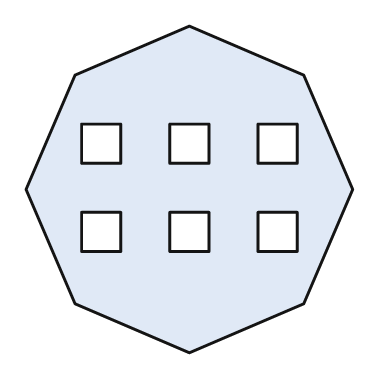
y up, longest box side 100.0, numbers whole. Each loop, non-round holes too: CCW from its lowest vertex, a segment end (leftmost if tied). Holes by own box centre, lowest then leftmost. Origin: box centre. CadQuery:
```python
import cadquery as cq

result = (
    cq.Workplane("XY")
    .moveTo(0.0, -50.0)
    .lineTo(35.0, -35.0)
    .lineTo(50.0, 0.0)
    .lineTo(35.0, 35.0)
    .lineTo(0.0, 50.0)
    .lineTo(-35.0, 35.0)
    .lineTo(-50.0, 0.0)
    .lineTo(-35.0, -35.0)
    .close()
    .moveTo(-33.0, -19.0)
    .lineTo(-21.0, -19.0)
    .lineTo(-21.0, -7.0)
    .lineTo(-33.0, -7.0)
    .close()
    .moveTo(-6.0, -19.0)
    .lineTo(6.0, -19.0)
    .lineTo(6.0, -7.0)
    .lineTo(-6.0, -7.0)
    .close()
    .moveTo(21.0, -19.0)
    .lineTo(33.0, -19.0)
    .lineTo(33.0, -7.0)
    .lineTo(21.0, -7.0)
    .close()
    .moveTo(-33.0, 8.0)
    .lineTo(-21.0, 8.0)
    .lineTo(-21.0, 20.0)
    .lineTo(-33.0, 20.0)
    .close()
    .moveTo(-6.0, 8.0)
    .lineTo(6.0, 8.0)
    .lineTo(6.0, 20.0)
    .lineTo(-6.0, 20.0)
    .close()
    .moveTo(21.0, 8.0)
    .lineTo(33.0, 8.0)
    .lineTo(33.0, 20.0)
    .lineTo(21.0, 20.0)
    .close()
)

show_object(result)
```